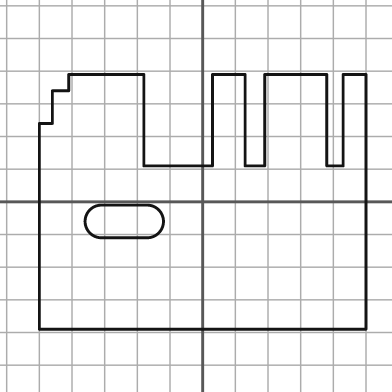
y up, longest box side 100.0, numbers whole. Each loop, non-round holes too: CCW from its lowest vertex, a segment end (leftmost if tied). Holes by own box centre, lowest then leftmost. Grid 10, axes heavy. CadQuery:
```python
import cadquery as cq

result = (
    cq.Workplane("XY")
    .moveTo(-50.0, -39.0)
    .lineTo(50.0, -39.0)
    .lineTo(50.0, 39.0)
    .lineTo(43.0, 39.0)
    .lineTo(43.0, 11.0)
    .lineTo(38.0, 11.0)
    .lineTo(38.0, 39.0)
    .lineTo(19.0, 39.0)
    .lineTo(19.0, 11.0)
    .lineTo(13.0, 11.0)
    .lineTo(13.0, 39.0)
    .lineTo(3.0, 39.0)
    .lineTo(3.0, 11.0)
    .lineTo(-18.0, 11.0)
    .lineTo(-18.0, 39.0)
    .lineTo(-41.0, 39.0)
    .lineTo(-41.0, 34.0)
    .lineTo(-46.0, 34.0)
    .lineTo(-46.0, 24.0)
    .lineTo(-50.0, 24.0)
    .close()
    .moveTo(-31.0, -11.0)
    .lineTo(-17.0, -11.0)
    .threePointArc((-12.0, -6.0), (-17.0, -1.0))
    .lineTo(-31.0, -1.0)
    .threePointArc((-36.0, -6.0), (-31.0, -11.0))
    .close()
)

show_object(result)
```